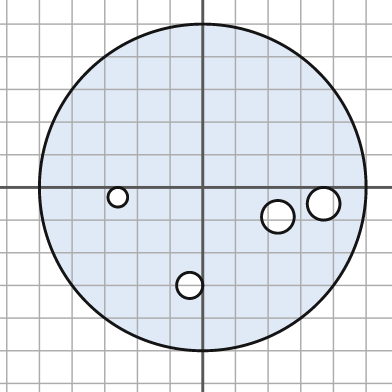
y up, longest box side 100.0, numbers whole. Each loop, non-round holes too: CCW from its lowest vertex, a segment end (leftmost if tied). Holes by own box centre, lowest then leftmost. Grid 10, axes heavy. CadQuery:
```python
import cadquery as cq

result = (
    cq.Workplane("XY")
    .moveTo(0.0, 0.0)
    .circle(50.0)
    .moveTo(-4.0, -30.0)
    .circle(4.0)
    .moveTo(23.0, -9.0)
    .circle(5.0)
    .moveTo(37.0, -5.0)
    .circle(5.0)
    .moveTo(-26.0, -3.0)
    .circle(3.0)
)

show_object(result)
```